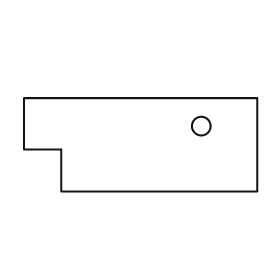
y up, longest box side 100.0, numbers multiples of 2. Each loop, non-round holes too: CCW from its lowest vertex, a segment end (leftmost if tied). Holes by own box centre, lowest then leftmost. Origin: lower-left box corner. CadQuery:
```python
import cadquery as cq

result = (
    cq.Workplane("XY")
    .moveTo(16.0, 0.0)
    .lineTo(100.0, 0.0)
    .lineTo(100.0, 40.0)
    .lineTo(0.0, 40.0)
    .lineTo(0.0, 18.0)
    .lineTo(16.0, 18.0)
    .close()
    .moveTo(76.0, 28.0)
    .circle(4.0)
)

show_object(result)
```